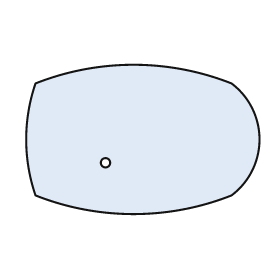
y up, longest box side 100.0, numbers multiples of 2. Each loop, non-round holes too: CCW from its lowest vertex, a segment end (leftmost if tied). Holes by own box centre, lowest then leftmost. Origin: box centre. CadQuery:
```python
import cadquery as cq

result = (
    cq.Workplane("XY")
    .moveTo(-46.0, -24.0)
    .threePointArc((-4.0, -32.0), (38.0, -24.0))
    .threePointArc((50.0, 0.0), (38.0, 24.0))
    .threePointArc((-4.0, 32.0), (-46.0, 24.0))
    .threePointArc((-50.0, 0.0), (-46.0, -24.0))
    .close()
    .moveTo(-16.0, -10.0)
    .circle(2.0)
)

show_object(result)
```